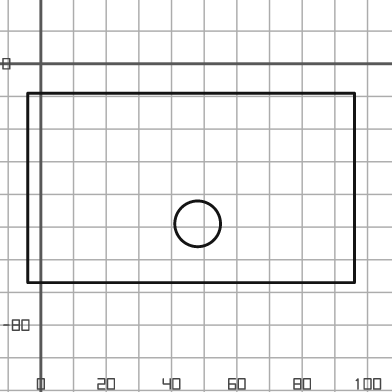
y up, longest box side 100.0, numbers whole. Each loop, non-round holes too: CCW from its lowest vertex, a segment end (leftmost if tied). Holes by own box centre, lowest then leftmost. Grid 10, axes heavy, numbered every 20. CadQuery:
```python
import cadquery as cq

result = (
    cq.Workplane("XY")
    .moveTo(-4.0, -67.0)
    .lineTo(96.0, -67.0)
    .lineTo(96.0, -9.0)
    .lineTo(-4.0, -9.0)
    .close()
    .moveTo(48.0, -49.0)
    .circle(7.0)
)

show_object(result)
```